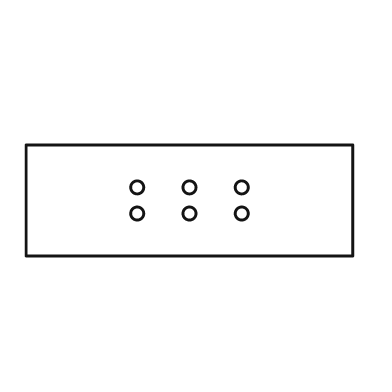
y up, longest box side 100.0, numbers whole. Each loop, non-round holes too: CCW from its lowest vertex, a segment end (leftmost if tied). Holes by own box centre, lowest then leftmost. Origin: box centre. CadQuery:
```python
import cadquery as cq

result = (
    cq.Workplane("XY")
    .moveTo(-50.0, -17.0)
    .lineTo(50.0, -17.0)
    .lineTo(50.0, 17.0)
    .lineTo(-50.0, 17.0)
    .close()
    .moveTo(-16.0, -4.0)
    .circle(2.0)
    .moveTo(0.0, -4.0)
    .circle(2.0)
    .moveTo(16.0, -4.0)
    .circle(2.0)
    .moveTo(-16.0, 4.0)
    .circle(2.0)
    .moveTo(0.0, 4.0)
    .circle(2.0)
    .moveTo(16.0, 4.0)
    .circle(2.0)
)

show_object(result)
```